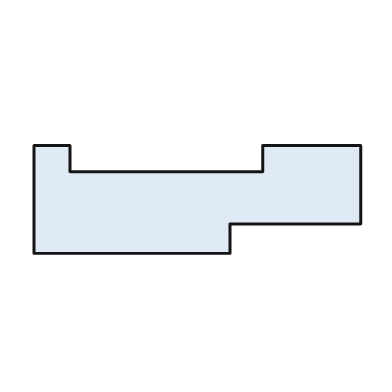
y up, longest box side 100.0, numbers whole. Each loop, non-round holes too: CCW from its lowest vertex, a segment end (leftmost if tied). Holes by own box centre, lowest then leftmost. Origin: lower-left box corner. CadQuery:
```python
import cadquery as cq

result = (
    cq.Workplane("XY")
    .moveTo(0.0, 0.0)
    .lineTo(60.0, 0.0)
    .lineTo(60.0, 9.0)
    .lineTo(100.0, 9.0)
    .lineTo(100.0, 33.0)
    .lineTo(70.0, 33.0)
    .lineTo(70.0, 25.0)
    .lineTo(11.0, 25.0)
    .lineTo(11.0, 33.0)
    .lineTo(0.0, 33.0)
    .close()
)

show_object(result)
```